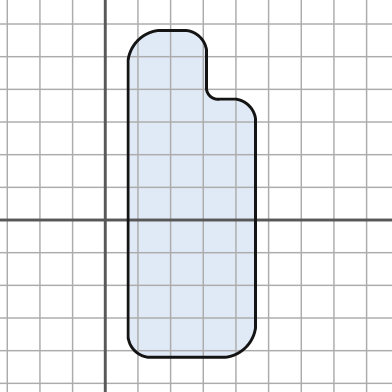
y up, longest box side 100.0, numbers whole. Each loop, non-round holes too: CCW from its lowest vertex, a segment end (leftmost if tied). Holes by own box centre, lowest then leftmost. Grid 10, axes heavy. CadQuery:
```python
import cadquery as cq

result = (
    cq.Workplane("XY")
    .moveTo(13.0, -42.0)
    .lineTo(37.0, -42.0)
    .threePointArc((43.0, -39.0), (46.0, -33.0))
    .lineTo(46.0, 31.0)
    .threePointArc((44.0, 35.0), (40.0, 37.0))
    .lineTo(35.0, 37.0)
    .threePointArc((32.0, 38.0), (31.0, 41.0))
    .lineTo(31.0, 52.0)
    .threePointArc((29.0, 56.0), (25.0, 58.0))
    .lineTo(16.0, 58.0)
    .threePointArc((10.0, 55.0), (7.0, 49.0))
    .lineTo(7.0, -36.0)
    .threePointArc((9.0, -40.0), (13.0, -42.0))
    .close()
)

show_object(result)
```